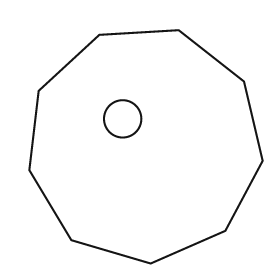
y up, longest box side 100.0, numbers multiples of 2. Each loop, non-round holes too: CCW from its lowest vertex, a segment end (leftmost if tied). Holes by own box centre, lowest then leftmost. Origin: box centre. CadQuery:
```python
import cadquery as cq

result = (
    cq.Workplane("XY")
    .moveTo(2.0, -50.0)
    .lineTo(34.0, -36.0)
    .lineTo(50.0, -6.0)
    .lineTo(42.0, 28.0)
    .lineTo(14.0, 50.0)
    .lineTo(-20.0, 48.0)
    .lineTo(-46.0, 24.0)
    .lineTo(-50.0, -10.0)
    .lineTo(-32.0, -40.0)
    .close()
    .moveTo(-10.0, 12.0)
    .circle(8.0)
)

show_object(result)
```